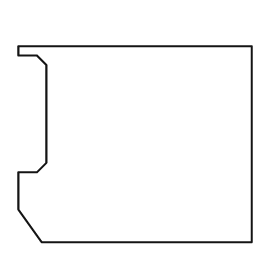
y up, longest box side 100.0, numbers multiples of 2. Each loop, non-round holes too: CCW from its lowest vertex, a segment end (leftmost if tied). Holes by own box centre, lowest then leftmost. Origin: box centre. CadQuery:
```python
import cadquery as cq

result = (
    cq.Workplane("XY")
    .moveTo(-40.0, -42.0)
    .lineTo(50.0, -42.0)
    .lineTo(50.0, 42.0)
    .lineTo(-50.0, 42.0)
    .lineTo(-50.0, 38.0)
    .lineTo(-42.0, 38.0)
    .lineTo(-38.0, 34.0)
    .lineTo(-38.0, -8.0)
    .lineTo(-42.0, -12.0)
    .lineTo(-50.0, -12.0)
    .lineTo(-50.0, -28.0)
    .close()
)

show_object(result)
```